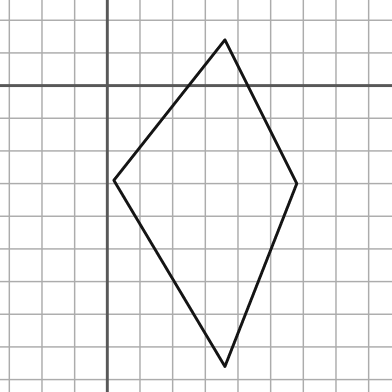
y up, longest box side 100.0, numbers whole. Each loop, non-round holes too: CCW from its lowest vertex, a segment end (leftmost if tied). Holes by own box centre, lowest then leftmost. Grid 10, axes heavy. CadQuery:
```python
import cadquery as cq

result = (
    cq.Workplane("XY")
    .moveTo(36.0, -86.0)
    .lineTo(58.0, -30.0)
    .lineTo(36.0, 14.0)
    .lineTo(2.0, -29.0)
    .close()
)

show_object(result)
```